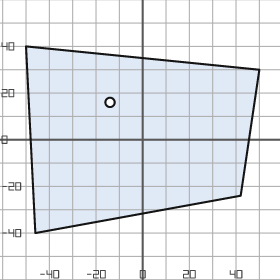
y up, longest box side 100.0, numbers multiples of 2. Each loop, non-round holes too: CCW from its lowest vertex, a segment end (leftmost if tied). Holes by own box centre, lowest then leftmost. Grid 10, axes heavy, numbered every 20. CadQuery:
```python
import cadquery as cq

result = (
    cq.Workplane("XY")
    .moveTo(-46.0, -40.0)
    .lineTo(42.0, -24.0)
    .lineTo(50.0, 30.0)
    .lineTo(-50.0, 40.0)
    .close()
    .moveTo(-14.0, 16.0)
    .circle(2.0)
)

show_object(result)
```